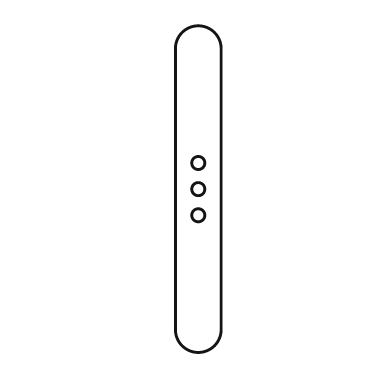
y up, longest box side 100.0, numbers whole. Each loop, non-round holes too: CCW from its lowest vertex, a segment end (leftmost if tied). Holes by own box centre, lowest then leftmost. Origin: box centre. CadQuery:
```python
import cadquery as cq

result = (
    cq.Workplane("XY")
    .moveTo(-7.0, -43.0)
    .threePointArc((0.0, -50.0), (7.0, -43.0))
    .lineTo(7.0, 43.0)
    .threePointArc((0.0, 50.0), (-7.0, 43.0))
    .close()
    .moveTo(0.0, -8.0)
    .circle(2.0)
    .moveTo(0.0, 0.0)
    .circle(2.0)
    .moveTo(0.0, 8.0)
    .circle(2.0)
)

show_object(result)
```